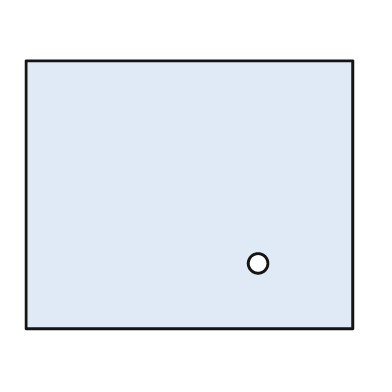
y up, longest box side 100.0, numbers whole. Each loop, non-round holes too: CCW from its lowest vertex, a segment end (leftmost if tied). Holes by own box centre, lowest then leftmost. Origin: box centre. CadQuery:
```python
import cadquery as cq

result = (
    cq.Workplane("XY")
    .moveTo(-50.0, -41.0)
    .lineTo(50.0, -41.0)
    .lineTo(50.0, 41.0)
    .lineTo(-50.0, 41.0)
    .close()
    .moveTo(21.0, -21.0)
    .circle(3.0)
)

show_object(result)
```